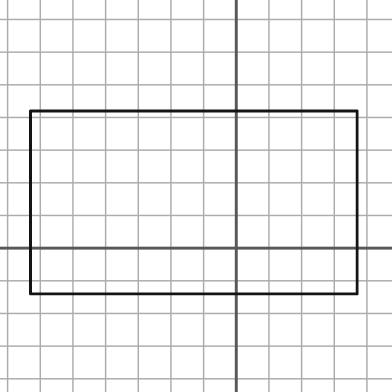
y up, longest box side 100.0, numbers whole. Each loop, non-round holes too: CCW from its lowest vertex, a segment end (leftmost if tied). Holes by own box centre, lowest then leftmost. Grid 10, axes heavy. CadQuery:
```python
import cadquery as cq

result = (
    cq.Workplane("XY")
    .moveTo(-63.0, -14.0)
    .lineTo(37.0, -14.0)
    .lineTo(37.0, 42.0)
    .lineTo(-63.0, 42.0)
    .close()
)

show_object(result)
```